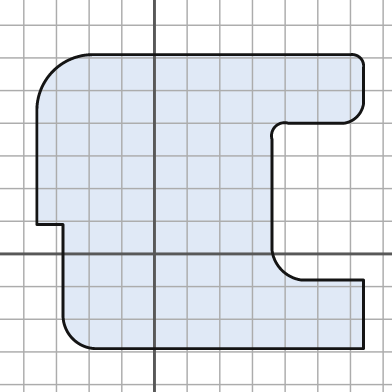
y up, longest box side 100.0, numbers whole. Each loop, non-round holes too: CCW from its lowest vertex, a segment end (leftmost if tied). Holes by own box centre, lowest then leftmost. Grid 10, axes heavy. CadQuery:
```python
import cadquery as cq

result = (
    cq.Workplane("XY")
    .moveTo(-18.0, -29.0)
    .lineTo(64.0, -29.0)
    .lineTo(64.0, -8.0)
    .lineTo(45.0, -8.0)
    .threePointArc((39.0, -5.0), (36.0, 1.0))
    .lineTo(36.0, 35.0)
    .threePointArc((37.0, 39.0), (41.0, 40.0))
    .lineTo(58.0, 40.0)
    .threePointArc((62.0, 42.0), (64.0, 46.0))
    .lineTo(64.0, 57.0)
    .threePointArc((63.0, 60.0), (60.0, 61.0))
    .lineTo(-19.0, 61.0)
    .threePointArc((-31.0, 56.0), (-36.0, 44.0))
    .lineTo(-36.0, 9.0)
    .lineTo(-28.0, 9.0)
    .lineTo(-28.0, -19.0)
    .threePointArc((-25.0, -26.0), (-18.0, -29.0))
    .close()
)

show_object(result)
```